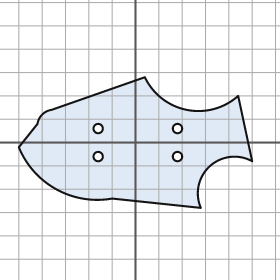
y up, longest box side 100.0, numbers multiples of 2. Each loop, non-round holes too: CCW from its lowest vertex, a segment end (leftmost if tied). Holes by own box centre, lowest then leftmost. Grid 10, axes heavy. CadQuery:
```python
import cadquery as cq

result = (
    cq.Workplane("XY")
    .moveTo(28.0, -28.0)
    .threePointArc((32.0, -10.0), (50.0, -8.0))
    .lineTo(44.0, 20.0)
    .threePointArc((22.0, 14.0), (4.0, 28.0))
    .lineTo(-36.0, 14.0)
    .threePointArc((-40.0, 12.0), (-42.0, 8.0))
    .lineTo(-50.0, -2.0)
    .threePointArc((-34.0, -20.0), (-10.0, -24.0))
    .close()
    .moveTo(-16.0, -6.0)
    .circle(2.0)
    .moveTo(18.0, -6.0)
    .circle(2.0)
    .moveTo(-16.0, 6.0)
    .circle(2.0)
    .moveTo(18.0, 6.0)
    .circle(2.0)
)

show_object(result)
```